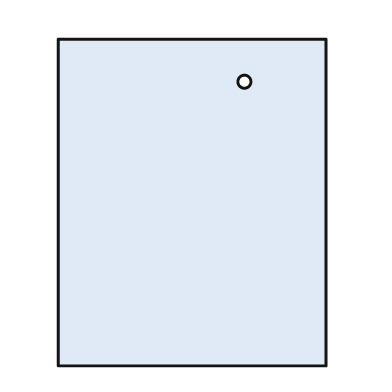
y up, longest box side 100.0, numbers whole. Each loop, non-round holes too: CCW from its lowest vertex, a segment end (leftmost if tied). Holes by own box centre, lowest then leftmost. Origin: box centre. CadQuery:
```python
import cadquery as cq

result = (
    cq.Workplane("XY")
    .moveTo(-41.0, -50.0)
    .lineTo(41.0, -50.0)
    .lineTo(41.0, 50.0)
    .lineTo(-41.0, 50.0)
    .close()
    .moveTo(16.0, 37.0)
    .circle(2.0)
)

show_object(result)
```